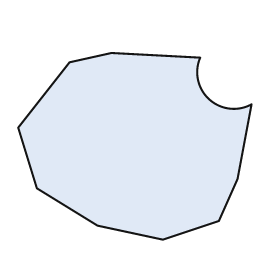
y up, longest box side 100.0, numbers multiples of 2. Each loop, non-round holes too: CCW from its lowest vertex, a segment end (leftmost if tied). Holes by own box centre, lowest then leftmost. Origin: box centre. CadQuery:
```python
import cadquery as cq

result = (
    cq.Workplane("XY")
    .moveTo(12.0, -40.0)
    .lineTo(36.0, -32.0)
    .lineTo(44.0, -14.0)
    .lineTo(50.0, 18.0)
    .threePointArc((32.0, 20.0), (28.0, 38.0))
    .lineTo(-10.0, 40.0)
    .lineTo(-28.0, 36.0)
    .lineTo(-50.0, 8.0)
    .lineTo(-42.0, -18.0)
    .lineTo(-16.0, -34.0)
    .close()
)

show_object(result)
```